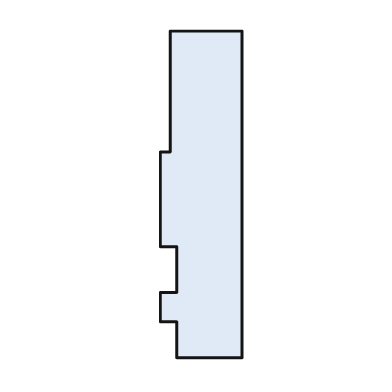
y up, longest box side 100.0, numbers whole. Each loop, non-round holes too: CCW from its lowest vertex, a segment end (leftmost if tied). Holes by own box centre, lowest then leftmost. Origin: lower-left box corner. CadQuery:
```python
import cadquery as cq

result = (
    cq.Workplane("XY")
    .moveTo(5.0, 0.0)
    .lineTo(25.0, 0.0)
    .lineTo(25.0, 100.0)
    .lineTo(3.0, 100.0)
    .lineTo(3.0, 63.0)
    .lineTo(0.0, 63.0)
    .lineTo(0.0, 34.0)
    .lineTo(5.0, 34.0)
    .lineTo(5.0, 20.0)
    .lineTo(0.0, 20.0)
    .lineTo(0.0, 11.0)
    .lineTo(5.0, 11.0)
    .close()
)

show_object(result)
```